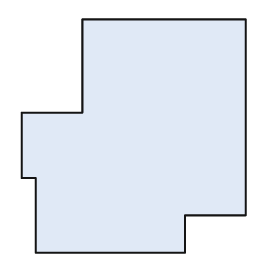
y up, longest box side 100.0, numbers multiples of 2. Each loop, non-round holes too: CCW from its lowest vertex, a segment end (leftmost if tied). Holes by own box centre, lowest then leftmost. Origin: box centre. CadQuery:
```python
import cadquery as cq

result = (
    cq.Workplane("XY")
    .moveTo(-42.0, -50.0)
    .lineTo(22.0, -50.0)
    .lineTo(22.0, -34.0)
    .lineTo(48.0, -34.0)
    .lineTo(48.0, 50.0)
    .lineTo(-22.0, 50.0)
    .lineTo(-22.0, 10.0)
    .lineTo(-48.0, 10.0)
    .lineTo(-48.0, -18.0)
    .lineTo(-42.0, -18.0)
    .close()
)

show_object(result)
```